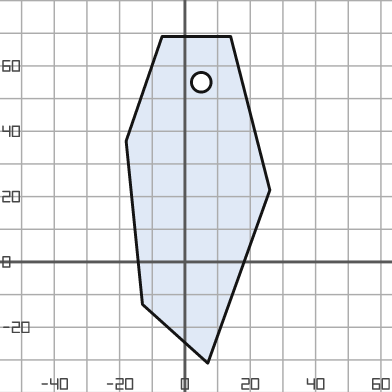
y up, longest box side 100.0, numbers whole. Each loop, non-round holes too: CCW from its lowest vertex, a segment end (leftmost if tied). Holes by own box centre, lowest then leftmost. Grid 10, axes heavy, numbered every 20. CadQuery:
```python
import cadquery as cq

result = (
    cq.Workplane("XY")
    .moveTo(7.0, -31.0)
    .lineTo(26.0, 22.0)
    .lineTo(14.0, 69.0)
    .lineTo(-7.0, 69.0)
    .lineTo(-18.0, 37.0)
    .lineTo(-13.0, -13.0)
    .close()
    .moveTo(5.0, 55.0)
    .circle(3.0)
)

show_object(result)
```